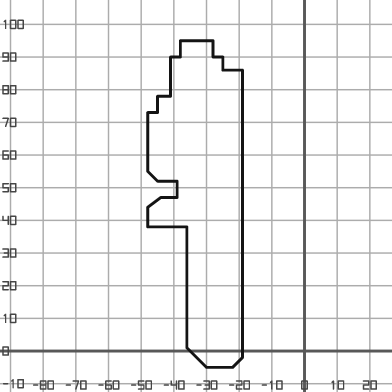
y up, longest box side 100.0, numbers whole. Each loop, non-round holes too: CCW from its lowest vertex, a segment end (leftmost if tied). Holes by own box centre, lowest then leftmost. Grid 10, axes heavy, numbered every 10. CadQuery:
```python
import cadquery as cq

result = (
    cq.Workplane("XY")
    .moveTo(-30.0, -5.0)
    .lineTo(-22.0, -5.0)
    .lineTo(-19.0, -2.0)
    .lineTo(-19.0, 86.0)
    .lineTo(-25.0, 86.0)
    .lineTo(-25.0, 90.0)
    .lineTo(-28.0, 90.0)
    .lineTo(-28.0, 95.0)
    .lineTo(-38.0, 95.0)
    .lineTo(-38.0, 90.0)
    .lineTo(-41.0, 90.0)
    .lineTo(-41.0, 78.0)
    .lineTo(-45.0, 78.0)
    .lineTo(-45.0, 73.0)
    .lineTo(-48.0, 73.0)
    .lineTo(-48.0, 55.0)
    .lineTo(-45.0, 52.0)
    .lineTo(-39.0, 52.0)
    .lineTo(-39.0, 47.0)
    .lineTo(-44.0, 47.0)
    .lineTo(-48.0, 44.0)
    .lineTo(-48.0, 38.0)
    .lineTo(-36.0, 38.0)
    .lineTo(-36.0, 1.0)
    .close()
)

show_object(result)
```